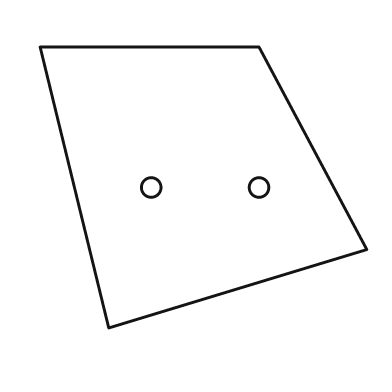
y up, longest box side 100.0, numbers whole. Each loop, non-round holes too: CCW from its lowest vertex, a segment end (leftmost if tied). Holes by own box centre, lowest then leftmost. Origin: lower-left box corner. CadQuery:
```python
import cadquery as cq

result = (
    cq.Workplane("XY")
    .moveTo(21.0, 0.0)
    .lineTo(100.0, 24.0)
    .lineTo(67.0, 86.0)
    .lineTo(0.0, 86.0)
    .close()
    .moveTo(34.0, 43.0)
    .circle(3.0)
    .moveTo(67.0, 43.0)
    .circle(3.0)
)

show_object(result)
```